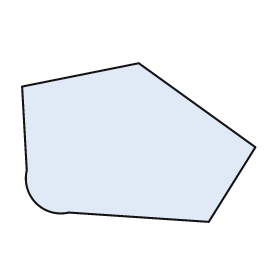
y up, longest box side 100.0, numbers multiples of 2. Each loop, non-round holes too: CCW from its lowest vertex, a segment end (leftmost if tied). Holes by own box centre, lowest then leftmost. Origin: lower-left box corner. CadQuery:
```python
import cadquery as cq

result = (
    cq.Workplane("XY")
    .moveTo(80.0, 0.0)
    .lineTo(100.0, 32.0)
    .lineTo(50.0, 68.0)
    .lineTo(0.0, 58.0)
    .lineTo(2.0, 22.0)
    .threePointArc((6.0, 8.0), (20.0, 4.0))
    .close()
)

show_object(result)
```